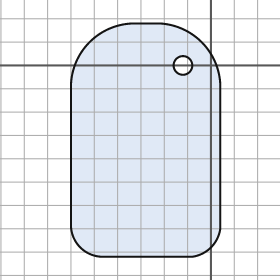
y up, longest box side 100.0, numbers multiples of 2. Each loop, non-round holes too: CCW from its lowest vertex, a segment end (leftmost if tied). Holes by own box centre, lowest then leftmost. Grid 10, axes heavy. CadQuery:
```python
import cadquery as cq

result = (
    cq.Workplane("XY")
    .moveTo(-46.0, -82.0)
    .lineTo(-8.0, -82.0)
    .threePointArc((0.0, -78.0), (4.0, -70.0))
    .lineTo(4.0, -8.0)
    .threePointArc((-4.0, 10.0), (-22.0, 18.0))
    .lineTo(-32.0, 18.0)
    .threePointArc((-52.0, 10.0), (-60.0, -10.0))
    .lineTo(-60.0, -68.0)
    .threePointArc((-56.0, -78.0), (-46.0, -82.0))
    .close()
    .moveTo(-12.0, 0.0)
    .circle(4.0)
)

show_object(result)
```